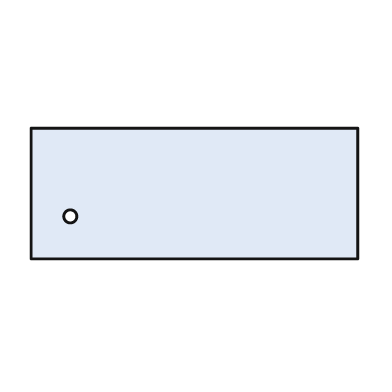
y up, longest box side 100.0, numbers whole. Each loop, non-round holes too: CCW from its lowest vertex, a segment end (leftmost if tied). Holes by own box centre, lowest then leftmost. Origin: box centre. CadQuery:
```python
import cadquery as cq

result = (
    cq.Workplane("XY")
    .moveTo(-50.0, -20.0)
    .lineTo(50.0, -20.0)
    .lineTo(50.0, 20.0)
    .lineTo(-50.0, 20.0)
    .close()
    .moveTo(-38.0, -7.0)
    .circle(2.0)
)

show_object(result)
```